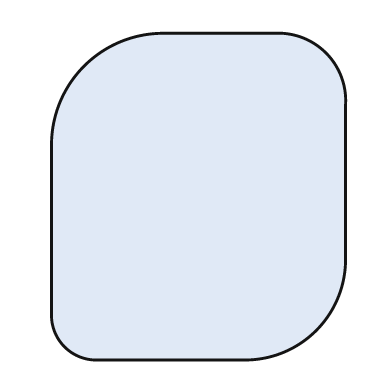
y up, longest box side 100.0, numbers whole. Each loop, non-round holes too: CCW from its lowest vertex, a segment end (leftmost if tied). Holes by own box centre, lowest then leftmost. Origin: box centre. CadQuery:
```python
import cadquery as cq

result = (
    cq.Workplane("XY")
    .moveTo(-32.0, -50.0)
    .lineTo(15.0, -50.0)
    .threePointArc((36.0, -41.0), (45.0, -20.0))
    .lineTo(45.0, 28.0)
    .threePointArc((39.0, 44.0), (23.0, 50.0))
    .lineTo(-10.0, 50.0)
    .threePointArc((-35.0, 40.0), (-45.0, 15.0))
    .lineTo(-45.0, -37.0)
    .threePointArc((-41.0, -46.0), (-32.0, -50.0))
    .close()
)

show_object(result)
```